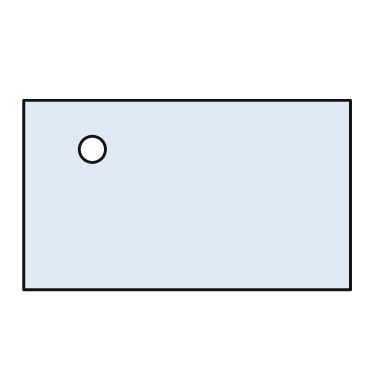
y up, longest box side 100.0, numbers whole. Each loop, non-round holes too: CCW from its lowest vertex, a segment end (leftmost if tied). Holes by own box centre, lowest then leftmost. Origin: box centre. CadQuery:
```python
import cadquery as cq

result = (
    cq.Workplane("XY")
    .moveTo(-50.0, -29.0)
    .lineTo(50.0, -29.0)
    .lineTo(50.0, 29.0)
    .lineTo(-50.0, 29.0)
    .close()
    .moveTo(-29.0, 14.0)
    .circle(4.0)
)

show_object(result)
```